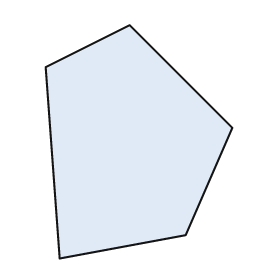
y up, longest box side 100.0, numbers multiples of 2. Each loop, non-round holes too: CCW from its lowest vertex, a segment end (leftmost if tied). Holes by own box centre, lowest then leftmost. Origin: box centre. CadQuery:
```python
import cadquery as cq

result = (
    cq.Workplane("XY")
    .moveTo(-34.0, -50.0)
    .lineTo(20.0, -40.0)
    .lineTo(40.0, 6.0)
    .lineTo(-4.0, 50.0)
    .lineTo(-40.0, 32.0)
    .close()
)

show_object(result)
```